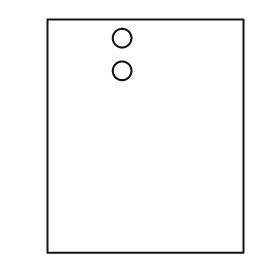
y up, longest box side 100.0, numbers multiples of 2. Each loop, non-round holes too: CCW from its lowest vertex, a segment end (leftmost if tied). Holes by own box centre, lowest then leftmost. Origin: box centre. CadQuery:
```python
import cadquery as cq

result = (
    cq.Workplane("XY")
    .moveTo(-42.0, -50.0)
    .lineTo(42.0, -50.0)
    .lineTo(42.0, 50.0)
    .lineTo(-42.0, 50.0)
    .close()
    .moveTo(-10.0, 28.0)
    .circle(4.0)
    .moveTo(-10.0, 42.0)
    .circle(4.0)
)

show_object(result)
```